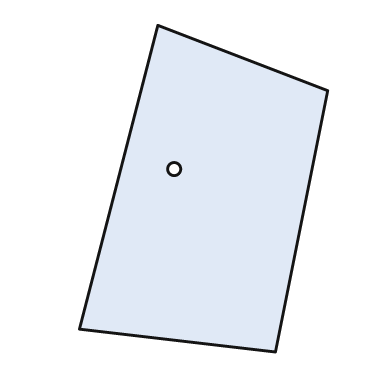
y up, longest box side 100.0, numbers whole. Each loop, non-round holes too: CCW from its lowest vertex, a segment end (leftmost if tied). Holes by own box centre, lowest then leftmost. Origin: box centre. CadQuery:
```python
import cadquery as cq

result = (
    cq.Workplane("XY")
    .moveTo(22.0, -50.0)
    .lineTo(38.0, 30.0)
    .lineTo(-14.0, 50.0)
    .lineTo(-38.0, -43.0)
    .close()
    .moveTo(-9.0, 6.0)
    .circle(2.0)
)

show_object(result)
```